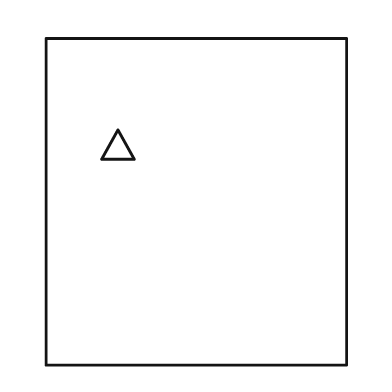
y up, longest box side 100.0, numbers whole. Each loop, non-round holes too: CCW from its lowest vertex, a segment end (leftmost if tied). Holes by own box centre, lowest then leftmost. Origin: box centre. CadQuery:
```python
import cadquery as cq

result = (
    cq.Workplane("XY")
    .moveTo(-46.0, -50.0)
    .lineTo(46.0, -50.0)
    .lineTo(46.0, 50.0)
    .lineTo(-46.0, 50.0)
    .close()
    .moveTo(-29.0, 13.0)
    .lineTo(-19.0, 13.0)
    .lineTo(-24.0, 22.0)
    .close()
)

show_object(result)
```